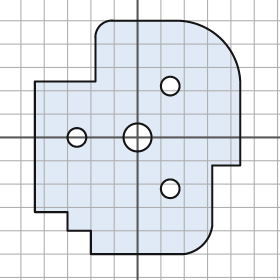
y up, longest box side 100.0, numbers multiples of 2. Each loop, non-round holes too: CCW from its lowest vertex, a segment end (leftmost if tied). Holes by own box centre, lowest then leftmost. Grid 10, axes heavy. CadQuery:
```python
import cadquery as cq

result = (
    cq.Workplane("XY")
    .moveTo(-20.0, -50.0)
    .lineTo(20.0, -50.0)
    .threePointArc((28.0, -46.0), (32.0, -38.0))
    .lineTo(32.0, -12.0)
    .lineTo(44.0, -12.0)
    .lineTo(44.0, 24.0)
    .threePointArc((36.0, 42.0), (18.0, 50.0))
    .lineTo(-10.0, 50.0)
    .threePointArc((-16.0, 48.0), (-18.0, 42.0))
    .lineTo(-18.0, 24.0)
    .lineTo(-44.0, 24.0)
    .lineTo(-44.0, -32.0)
    .lineTo(-30.0, -32.0)
    .lineTo(-30.0, -40.0)
    .lineTo(-20.0, -40.0)
    .close()
    .moveTo(14.0, -22.0)
    .circle(4.0)
    .moveTo(-26.0, 0.0)
    .circle(4.0)
    .moveTo(0.0, 0.0)
    .circle(6.0)
    .moveTo(14.0, 22.0)
    .circle(4.0)
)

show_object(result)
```